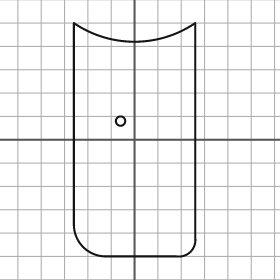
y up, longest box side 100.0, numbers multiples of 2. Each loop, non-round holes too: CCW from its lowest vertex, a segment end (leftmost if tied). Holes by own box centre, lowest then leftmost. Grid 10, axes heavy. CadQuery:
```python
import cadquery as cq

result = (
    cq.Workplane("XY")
    .moveTo(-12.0, -50.0)
    .lineTo(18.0, -50.0)
    .threePointArc((24.0, -48.0), (26.0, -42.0))
    .lineTo(26.0, 50.0)
    .threePointArc((0.0, 42.0), (-26.0, 50.0))
    .lineTo(-26.0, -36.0)
    .threePointArc((-22.0, -46.0), (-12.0, -50.0))
    .close()
    .moveTo(-6.0, 8.0)
    .circle(2.0)
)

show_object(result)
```